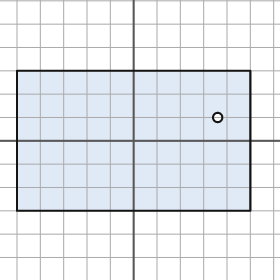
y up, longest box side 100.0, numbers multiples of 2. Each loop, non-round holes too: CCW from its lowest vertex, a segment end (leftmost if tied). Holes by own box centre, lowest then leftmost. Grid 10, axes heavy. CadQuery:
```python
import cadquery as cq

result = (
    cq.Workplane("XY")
    .moveTo(-50.0, -30.0)
    .lineTo(50.0, -30.0)
    .lineTo(50.0, 30.0)
    .lineTo(-50.0, 30.0)
    .close()
    .moveTo(36.0, 10.0)
    .circle(2.0)
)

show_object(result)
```